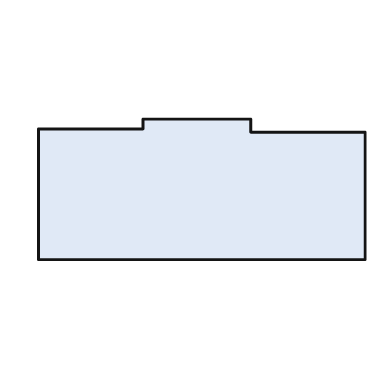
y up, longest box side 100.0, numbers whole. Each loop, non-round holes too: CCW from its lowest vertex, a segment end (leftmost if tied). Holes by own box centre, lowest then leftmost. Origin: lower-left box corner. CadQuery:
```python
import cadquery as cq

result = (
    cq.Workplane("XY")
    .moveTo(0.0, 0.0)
    .lineTo(100.0, 0.0)
    .lineTo(100.0, 39.0)
    .lineTo(65.0, 39.0)
    .lineTo(65.0, 43.0)
    .lineTo(32.0, 43.0)
    .lineTo(32.0, 40.0)
    .lineTo(0.0, 40.0)
    .close()
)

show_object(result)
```